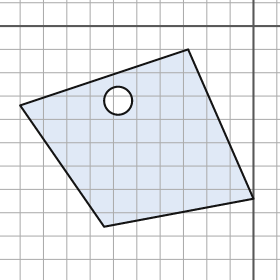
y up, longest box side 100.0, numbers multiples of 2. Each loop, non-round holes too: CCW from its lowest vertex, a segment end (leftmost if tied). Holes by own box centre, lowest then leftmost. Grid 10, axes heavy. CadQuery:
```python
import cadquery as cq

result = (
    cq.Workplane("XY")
    .moveTo(-64.0, -86.0)
    .lineTo(0.0, -74.0)
    .lineTo(-28.0, -10.0)
    .lineTo(-100.0, -34.0)
    .close()
    .moveTo(-58.0, -32.0)
    .circle(6.0)
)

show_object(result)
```